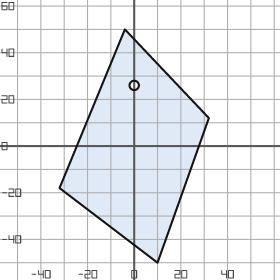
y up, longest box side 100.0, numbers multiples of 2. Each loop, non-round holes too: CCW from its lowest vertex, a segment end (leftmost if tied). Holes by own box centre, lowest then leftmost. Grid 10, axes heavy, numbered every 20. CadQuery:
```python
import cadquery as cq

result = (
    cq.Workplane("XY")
    .moveTo(10.0, -50.0)
    .lineTo(32.0, 12.0)
    .lineTo(-4.0, 50.0)
    .lineTo(-32.0, -18.0)
    .close()
    .moveTo(0.0, 26.0)
    .circle(2.0)
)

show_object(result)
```